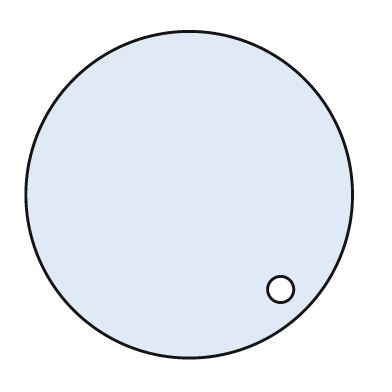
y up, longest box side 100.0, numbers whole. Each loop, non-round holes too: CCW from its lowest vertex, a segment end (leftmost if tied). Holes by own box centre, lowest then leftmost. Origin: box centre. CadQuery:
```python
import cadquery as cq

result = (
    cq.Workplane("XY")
    .moveTo(0.0, 0.0)
    .circle(50.0)
    .moveTo(28.0, -29.0)
    .circle(4.0)
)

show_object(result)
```